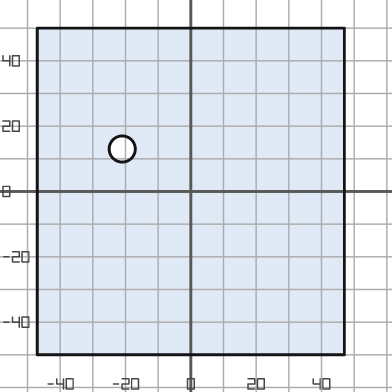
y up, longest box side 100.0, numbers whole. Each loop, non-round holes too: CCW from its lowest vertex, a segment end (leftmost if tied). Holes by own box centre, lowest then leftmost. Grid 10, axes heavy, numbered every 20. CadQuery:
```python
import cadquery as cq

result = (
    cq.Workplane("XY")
    .moveTo(-47.0, -50.0)
    .lineTo(47.0, -50.0)
    .lineTo(47.0, 50.0)
    .lineTo(-47.0, 50.0)
    .close()
    .moveTo(-21.0, 13.0)
    .circle(4.0)
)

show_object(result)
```